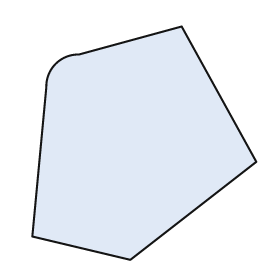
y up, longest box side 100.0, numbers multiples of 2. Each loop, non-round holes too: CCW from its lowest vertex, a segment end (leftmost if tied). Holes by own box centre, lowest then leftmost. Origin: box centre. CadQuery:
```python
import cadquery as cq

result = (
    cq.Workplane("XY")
    .moveTo(-6.0, -50.0)
    .lineTo(48.0, -8.0)
    .lineTo(16.0, 50.0)
    .lineTo(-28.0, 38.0)
    .threePointArc((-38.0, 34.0), (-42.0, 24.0))
    .lineTo(-48.0, -40.0)
    .close()
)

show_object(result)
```